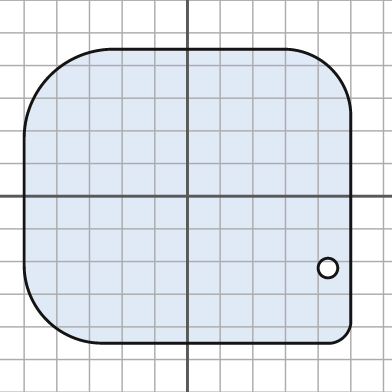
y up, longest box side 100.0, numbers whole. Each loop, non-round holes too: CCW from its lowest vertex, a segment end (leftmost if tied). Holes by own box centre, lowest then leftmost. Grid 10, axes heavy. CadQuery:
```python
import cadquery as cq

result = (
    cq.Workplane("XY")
    .moveTo(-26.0, -45.0)
    .lineTo(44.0, -45.0)
    .threePointArc((48.0, -43.0), (50.0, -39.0))
    .lineTo(50.0, 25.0)
    .threePointArc((44.0, 39.0), (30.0, 45.0))
    .lineTo(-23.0, 45.0)
    .threePointArc((-42.0, 37.0), (-50.0, 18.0))
    .lineTo(-50.0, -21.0)
    .threePointArc((-43.0, -38.0), (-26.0, -45.0))
    .close()
    .moveTo(43.0, -22.0)
    .circle(3.0)
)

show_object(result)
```